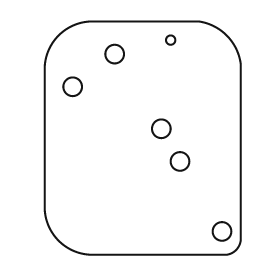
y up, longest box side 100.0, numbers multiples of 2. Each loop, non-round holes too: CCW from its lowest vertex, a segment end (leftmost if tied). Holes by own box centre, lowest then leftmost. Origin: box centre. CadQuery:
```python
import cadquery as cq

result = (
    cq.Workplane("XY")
    .moveTo(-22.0, -50.0)
    .lineTo(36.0, -50.0)
    .threePointArc((40.0, -48.0), (42.0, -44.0))
    .lineTo(42.0, 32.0)
    .threePointArc((36.0, 44.0), (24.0, 50.0))
    .lineTo(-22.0, 50.0)
    .threePointArc((-36.0, 44.0), (-42.0, 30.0))
    .lineTo(-42.0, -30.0)
    .threePointArc((-36.0, -44.0), (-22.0, -50.0))
    .close()
    .moveTo(34.0, -40.0)
    .circle(4.0)
    .moveTo(16.0, -10.0)
    .circle(4.0)
    .moveTo(8.0, 4.0)
    .circle(4.0)
    .moveTo(-30.0, 22.0)
    .circle(4.0)
    .moveTo(-12.0, 36.0)
    .circle(4.0)
    .moveTo(12.0, 42.0)
    .circle(2.0)
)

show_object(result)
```